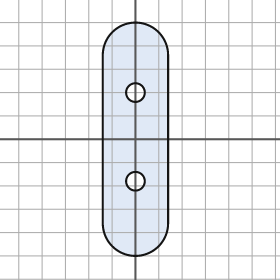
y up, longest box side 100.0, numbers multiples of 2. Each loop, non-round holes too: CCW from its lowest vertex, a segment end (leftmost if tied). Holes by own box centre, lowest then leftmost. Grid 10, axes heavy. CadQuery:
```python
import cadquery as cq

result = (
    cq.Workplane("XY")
    .moveTo(-14.0, -36.0)
    .threePointArc((0.0, -50.0), (14.0, -36.0))
    .lineTo(14.0, 36.0)
    .threePointArc((0.0, 50.0), (-14.0, 36.0))
    .close()
    .moveTo(0.0, -18.0)
    .circle(4.0)
    .moveTo(0.0, 20.0)
    .circle(4.0)
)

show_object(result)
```